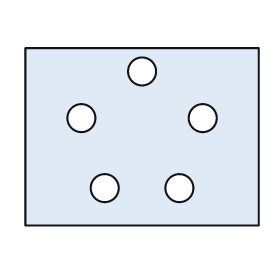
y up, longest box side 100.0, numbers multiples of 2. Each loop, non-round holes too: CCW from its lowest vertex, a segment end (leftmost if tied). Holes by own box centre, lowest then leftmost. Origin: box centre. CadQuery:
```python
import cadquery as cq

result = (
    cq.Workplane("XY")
    .moveTo(-50.0, -38.0)
    .lineTo(50.0, -38.0)
    .lineTo(50.0, 38.0)
    .lineTo(-50.0, 38.0)
    .close()
    .moveTo(-16.0, -22.0)
    .circle(6.0)
    .moveTo(16.0, -22.0)
    .circle(6.0)
    .moveTo(-26.0, 8.0)
    .circle(6.0)
    .moveTo(26.0, 8.0)
    .circle(6.0)
    .moveTo(0.0, 28.0)
    .circle(6.0)
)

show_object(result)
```